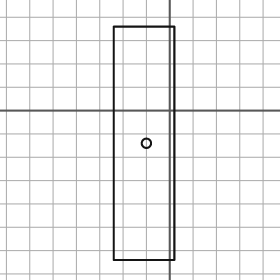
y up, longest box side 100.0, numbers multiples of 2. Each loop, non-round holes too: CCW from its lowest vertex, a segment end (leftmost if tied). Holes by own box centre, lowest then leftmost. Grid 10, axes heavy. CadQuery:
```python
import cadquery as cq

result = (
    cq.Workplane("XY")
    .moveTo(-24.0, -64.0)
    .lineTo(2.0, -64.0)
    .lineTo(2.0, 36.0)
    .lineTo(-24.0, 36.0)
    .close()
    .moveTo(-10.0, -14.0)
    .circle(2.0)
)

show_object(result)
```